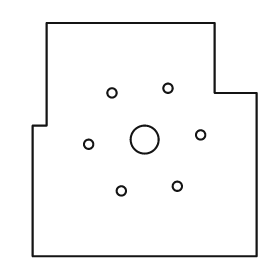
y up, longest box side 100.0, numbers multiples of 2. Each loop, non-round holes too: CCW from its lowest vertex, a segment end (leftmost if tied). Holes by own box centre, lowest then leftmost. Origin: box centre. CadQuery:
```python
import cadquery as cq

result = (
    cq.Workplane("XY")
    .moveTo(-48.0, -50.0)
    .lineTo(48.0, -50.0)
    .lineTo(48.0, 20.0)
    .lineTo(30.0, 20.0)
    .lineTo(30.0, 50.0)
    .lineTo(-42.0, 50.0)
    .lineTo(-42.0, 6.0)
    .lineTo(-48.0, 6.0)
    .close()
    .moveTo(-10.0, -22.0)
    .circle(2.0)
    .moveTo(14.0, -20.0)
    .circle(2.0)
    .moveTo(-24.0, -2.0)
    .circle(2.0)
    .moveTo(0.0, 0.0)
    .circle(6.0)
    .moveTo(24.0, 2.0)
    .circle(2.0)
    .moveTo(-14.0, 20.0)
    .circle(2.0)
    .moveTo(10.0, 22.0)
    .circle(2.0)
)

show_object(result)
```